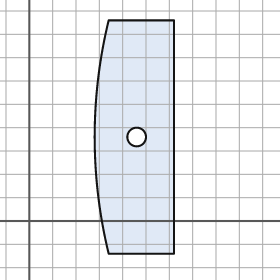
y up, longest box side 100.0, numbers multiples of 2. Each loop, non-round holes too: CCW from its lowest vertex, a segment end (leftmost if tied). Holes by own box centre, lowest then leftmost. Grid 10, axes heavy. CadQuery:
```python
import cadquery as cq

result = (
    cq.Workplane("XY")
    .moveTo(34.0, -14.0)
    .lineTo(62.0, -14.0)
    .lineTo(62.0, 86.0)
    .lineTo(34.0, 86.0)
    .threePointArc((28.0, 36.0), (34.0, -14.0))
    .close()
    .moveTo(46.0, 36.0)
    .circle(4.0)
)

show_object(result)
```